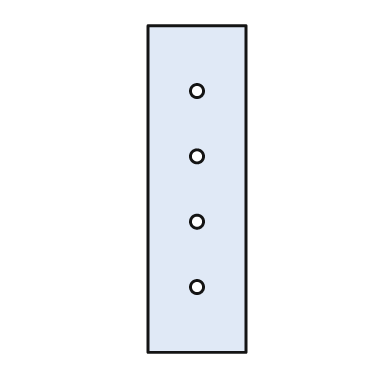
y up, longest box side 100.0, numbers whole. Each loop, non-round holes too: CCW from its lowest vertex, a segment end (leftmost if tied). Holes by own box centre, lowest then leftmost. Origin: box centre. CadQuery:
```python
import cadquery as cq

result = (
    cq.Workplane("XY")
    .moveTo(-15.0, -50.0)
    .lineTo(15.0, -50.0)
    .lineTo(15.0, 50.0)
    .lineTo(-15.0, 50.0)
    .close()
    .moveTo(0.0, -30.0)
    .circle(2.0)
    .moveTo(0.0, -10.0)
    .circle(2.0)
    .moveTo(0.0, 10.0)
    .circle(2.0)
    .moveTo(0.0, 30.0)
    .circle(2.0)
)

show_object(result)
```